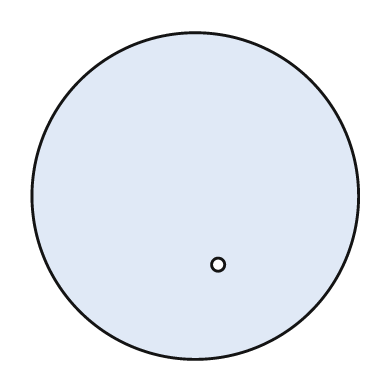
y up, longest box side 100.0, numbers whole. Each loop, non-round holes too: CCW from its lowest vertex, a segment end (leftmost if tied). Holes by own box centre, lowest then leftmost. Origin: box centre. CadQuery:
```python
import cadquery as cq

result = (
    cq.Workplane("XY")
    .moveTo(0.0, 0.0)
    .circle(50.0)
    .moveTo(7.0, -21.0)
    .circle(2.0)
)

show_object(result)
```